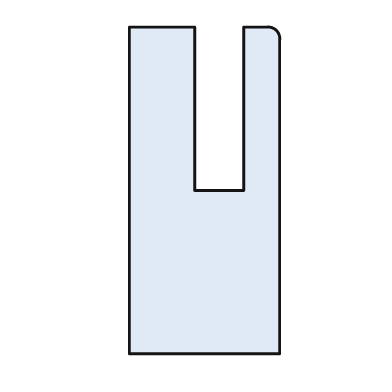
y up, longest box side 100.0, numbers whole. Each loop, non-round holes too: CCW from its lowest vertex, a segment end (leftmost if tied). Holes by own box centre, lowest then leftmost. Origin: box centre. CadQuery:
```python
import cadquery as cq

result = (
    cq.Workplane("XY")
    .moveTo(-23.0, -50.0)
    .lineTo(23.0, -50.0)
    .lineTo(23.0, 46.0)
    .threePointArc((22.0, 49.0), (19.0, 50.0))
    .lineTo(12.0, 50.0)
    .lineTo(12.0, 0.0)
    .lineTo(-3.0, 0.0)
    .lineTo(-3.0, 50.0)
    .lineTo(-23.0, 50.0)
    .close()
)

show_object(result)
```